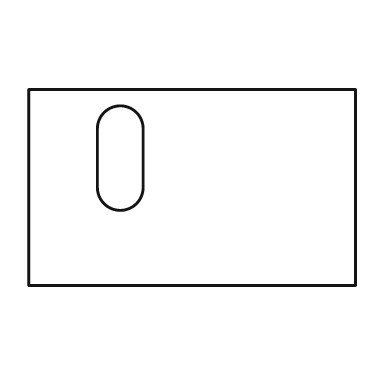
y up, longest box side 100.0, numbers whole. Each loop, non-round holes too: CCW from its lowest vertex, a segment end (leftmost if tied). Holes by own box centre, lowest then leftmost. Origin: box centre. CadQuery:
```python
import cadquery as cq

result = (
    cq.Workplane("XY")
    .moveTo(-50.0, -30.0)
    .lineTo(50.0, -30.0)
    .lineTo(50.0, 30.0)
    .lineTo(-50.0, 30.0)
    .close()
    .moveTo(-29.0, 0.0)
    .threePointArc((-22.0, -7.0), (-15.0, 0.0))
    .lineTo(-15.0, 18.0)
    .threePointArc((-22.0, 25.0), (-29.0, 18.0))
    .close()
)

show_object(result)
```